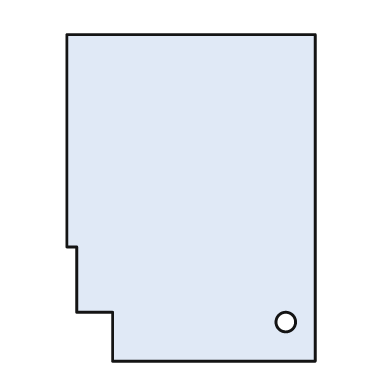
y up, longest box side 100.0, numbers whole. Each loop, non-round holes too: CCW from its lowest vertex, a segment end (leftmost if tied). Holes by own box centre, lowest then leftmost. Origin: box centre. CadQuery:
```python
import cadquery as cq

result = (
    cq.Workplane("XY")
    .moveTo(-24.0, -50.0)
    .lineTo(38.0, -50.0)
    .lineTo(38.0, 50.0)
    .lineTo(-38.0, 50.0)
    .lineTo(-38.0, -15.0)
    .lineTo(-35.0, -15.0)
    .lineTo(-35.0, -35.0)
    .lineTo(-24.0, -35.0)
    .close()
    .moveTo(29.0, -38.0)
    .circle(3.0)
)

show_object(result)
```